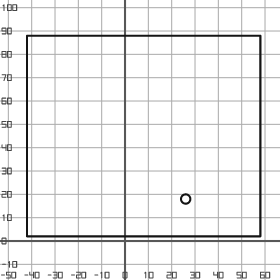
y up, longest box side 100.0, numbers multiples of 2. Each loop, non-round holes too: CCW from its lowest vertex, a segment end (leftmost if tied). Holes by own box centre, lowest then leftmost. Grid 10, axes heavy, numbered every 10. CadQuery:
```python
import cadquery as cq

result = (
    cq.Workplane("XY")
    .moveTo(-42.0, 2.0)
    .lineTo(58.0, 2.0)
    .lineTo(58.0, 88.0)
    .lineTo(-42.0, 88.0)
    .close()
    .moveTo(26.0, 18.0)
    .circle(2.0)
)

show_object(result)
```